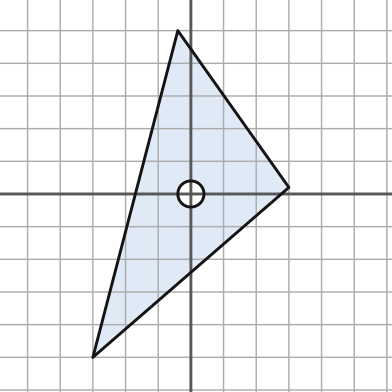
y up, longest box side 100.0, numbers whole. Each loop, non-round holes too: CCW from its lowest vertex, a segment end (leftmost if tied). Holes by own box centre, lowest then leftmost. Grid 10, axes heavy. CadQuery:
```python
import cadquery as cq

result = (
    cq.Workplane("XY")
    .moveTo(-30.0, -50.0)
    .lineTo(30.0, 2.0)
    .lineTo(-4.0, 50.0)
    .close()
    .moveTo(0.0, 0.0)
    .circle(4.0)
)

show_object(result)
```